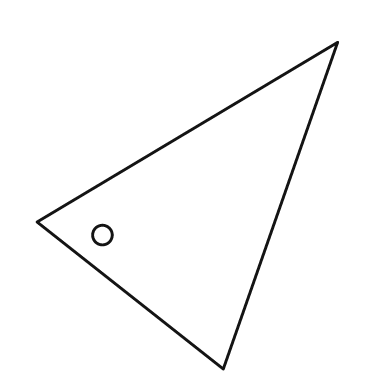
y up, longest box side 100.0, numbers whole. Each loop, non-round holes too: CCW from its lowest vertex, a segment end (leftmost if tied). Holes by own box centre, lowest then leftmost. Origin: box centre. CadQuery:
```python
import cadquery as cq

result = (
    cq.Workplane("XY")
    .moveTo(11.0, -50.0)
    .lineTo(46.0, 50.0)
    .lineTo(-46.0, -5.0)
    .close()
    .moveTo(-26.0, -9.0)
    .circle(3.0)
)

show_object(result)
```